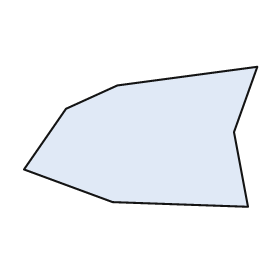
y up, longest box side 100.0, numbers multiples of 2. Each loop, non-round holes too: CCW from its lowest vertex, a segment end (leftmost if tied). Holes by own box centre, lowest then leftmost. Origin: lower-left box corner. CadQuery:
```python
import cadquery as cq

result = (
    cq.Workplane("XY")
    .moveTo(96.0, 0.0)
    .lineTo(90.0, 32.0)
    .lineTo(100.0, 60.0)
    .lineTo(40.0, 52.0)
    .lineTo(18.0, 42.0)
    .lineTo(0.0, 16.0)
    .lineTo(38.0, 2.0)
    .close()
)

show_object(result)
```